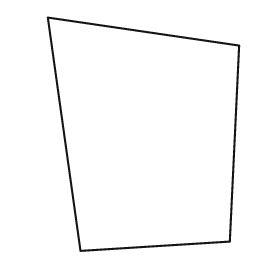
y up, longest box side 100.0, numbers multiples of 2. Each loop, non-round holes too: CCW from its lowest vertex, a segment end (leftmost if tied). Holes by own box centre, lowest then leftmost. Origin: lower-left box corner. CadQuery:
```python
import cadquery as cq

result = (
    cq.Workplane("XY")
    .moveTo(14.0, 0.0)
    .lineTo(78.0, 4.0)
    .lineTo(82.0, 88.0)
    .lineTo(0.0, 100.0)
    .close()
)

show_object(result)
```